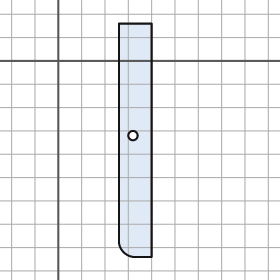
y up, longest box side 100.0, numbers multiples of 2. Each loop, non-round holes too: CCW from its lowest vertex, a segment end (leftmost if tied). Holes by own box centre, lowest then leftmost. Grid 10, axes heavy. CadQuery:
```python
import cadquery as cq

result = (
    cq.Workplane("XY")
    .moveTo(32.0, -84.0)
    .lineTo(40.0, -84.0)
    .lineTo(40.0, 16.0)
    .lineTo(26.0, 16.0)
    .lineTo(26.0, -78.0)
    .threePointArc((28.0, -82.0), (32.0, -84.0))
    .close()
    .moveTo(32.0, -32.0)
    .circle(2.0)
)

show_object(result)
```